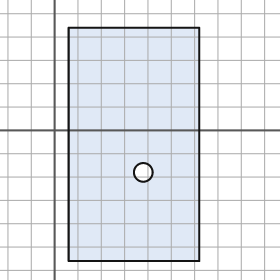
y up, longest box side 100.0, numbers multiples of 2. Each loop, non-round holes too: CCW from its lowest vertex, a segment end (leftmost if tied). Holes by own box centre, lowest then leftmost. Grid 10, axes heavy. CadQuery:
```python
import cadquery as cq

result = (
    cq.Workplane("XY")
    .moveTo(6.0, -56.0)
    .lineTo(62.0, -56.0)
    .lineTo(62.0, 44.0)
    .lineTo(6.0, 44.0)
    .close()
    .moveTo(38.0, -18.0)
    .circle(4.0)
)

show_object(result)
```